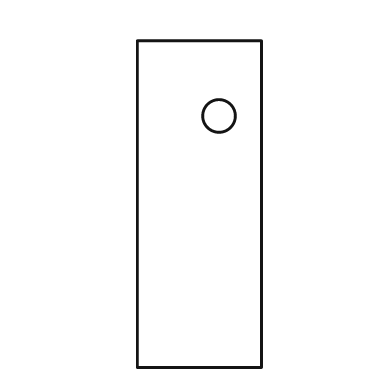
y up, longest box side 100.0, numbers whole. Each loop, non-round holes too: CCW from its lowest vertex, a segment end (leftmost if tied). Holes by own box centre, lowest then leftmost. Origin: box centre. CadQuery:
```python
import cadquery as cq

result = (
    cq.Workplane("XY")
    .moveTo(-19.0, -50.0)
    .lineTo(19.0, -50.0)
    .lineTo(19.0, 50.0)
    .lineTo(-19.0, 50.0)
    .close()
    .moveTo(6.0, 27.0)
    .circle(5.0)
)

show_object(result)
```